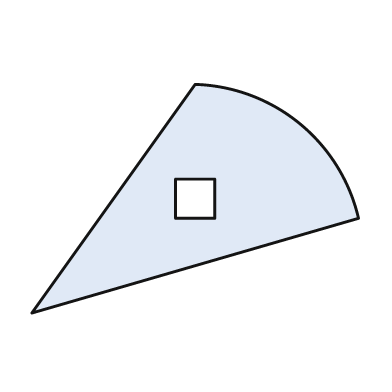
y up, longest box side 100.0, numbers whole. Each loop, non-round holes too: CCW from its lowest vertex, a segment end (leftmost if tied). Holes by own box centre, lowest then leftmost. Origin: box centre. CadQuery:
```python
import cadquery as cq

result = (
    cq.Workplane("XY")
    .moveTo(-50.0, -35.0)
    .lineTo(50.0, -6.0)
    .threePointArc((32.0, 23.0), (0.0, 35.0))
    .close()
    .moveTo(-6.0, -6.0)
    .lineTo(6.0, -6.0)
    .lineTo(6.0, 6.0)
    .lineTo(-6.0, 6.0)
    .close()
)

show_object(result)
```